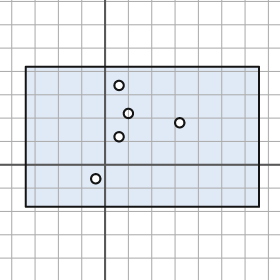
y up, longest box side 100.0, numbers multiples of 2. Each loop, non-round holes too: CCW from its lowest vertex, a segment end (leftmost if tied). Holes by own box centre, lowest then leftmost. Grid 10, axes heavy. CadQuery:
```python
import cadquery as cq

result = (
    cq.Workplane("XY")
    .moveTo(-34.0, -18.0)
    .lineTo(66.0, -18.0)
    .lineTo(66.0, 42.0)
    .lineTo(-34.0, 42.0)
    .close()
    .moveTo(-4.0, -6.0)
    .circle(2.0)
    .moveTo(6.0, 12.0)
    .circle(2.0)
    .moveTo(32.0, 18.0)
    .circle(2.0)
    .moveTo(10.0, 22.0)
    .circle(2.0)
    .moveTo(6.0, 34.0)
    .circle(2.0)
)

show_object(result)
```